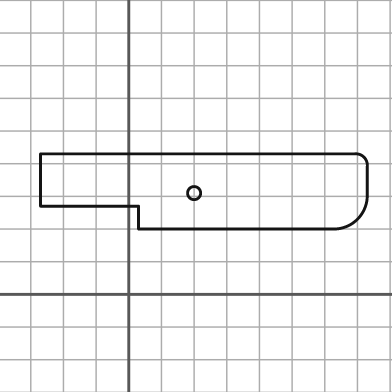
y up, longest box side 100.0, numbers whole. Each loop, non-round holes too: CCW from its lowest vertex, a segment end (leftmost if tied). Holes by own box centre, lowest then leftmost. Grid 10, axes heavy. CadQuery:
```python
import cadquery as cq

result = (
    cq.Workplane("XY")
    .moveTo(3.0, 20.0)
    .lineTo(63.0, 20.0)
    .threePointArc((70.0, 23.0), (73.0, 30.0))
    .lineTo(73.0, 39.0)
    .threePointArc((72.0, 42.0), (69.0, 43.0))
    .lineTo(-27.0, 43.0)
    .lineTo(-27.0, 27.0)
    .lineTo(3.0, 27.0)
    .close()
    .moveTo(20.0, 31.0)
    .circle(2.0)
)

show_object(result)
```